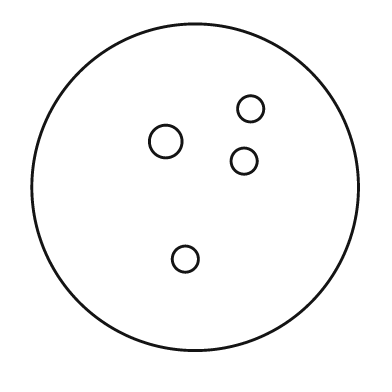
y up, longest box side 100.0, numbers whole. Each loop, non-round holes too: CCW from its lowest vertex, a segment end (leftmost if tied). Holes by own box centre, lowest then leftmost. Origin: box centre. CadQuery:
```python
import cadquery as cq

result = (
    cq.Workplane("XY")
    .moveTo(0.0, 0.0)
    .circle(50.0)
    .moveTo(-3.0, -22.0)
    .circle(4.0)
    .moveTo(15.0, 8.0)
    .circle(4.0)
    .moveTo(-9.0, 14.0)
    .circle(5.0)
    .moveTo(17.0, 24.0)
    .circle(4.0)
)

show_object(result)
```